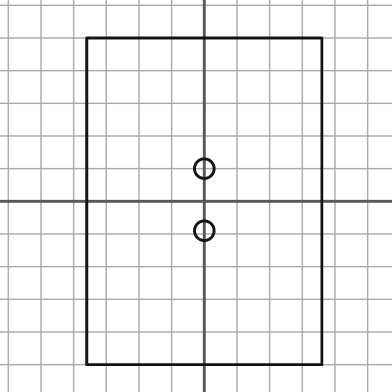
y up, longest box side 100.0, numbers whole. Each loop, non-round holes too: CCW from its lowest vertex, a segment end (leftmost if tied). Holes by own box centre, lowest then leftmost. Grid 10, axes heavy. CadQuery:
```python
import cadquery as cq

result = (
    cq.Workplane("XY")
    .moveTo(-36.0, -50.0)
    .lineTo(36.0, -50.0)
    .lineTo(36.0, 50.0)
    .lineTo(-36.0, 50.0)
    .close()
    .moveTo(0.0, -9.0)
    .circle(3.0)
    .moveTo(0.0, 10.0)
    .circle(3.0)
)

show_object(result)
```